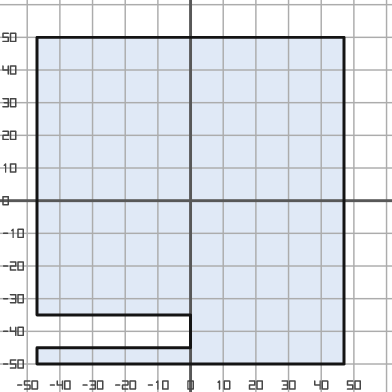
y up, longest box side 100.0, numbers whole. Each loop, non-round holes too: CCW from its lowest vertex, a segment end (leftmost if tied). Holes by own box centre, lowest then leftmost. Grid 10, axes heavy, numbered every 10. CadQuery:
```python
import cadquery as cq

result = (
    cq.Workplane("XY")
    .moveTo(-47.0, -50.0)
    .lineTo(47.0, -50.0)
    .lineTo(47.0, 50.0)
    .lineTo(-47.0, 50.0)
    .lineTo(-47.0, -35.0)
    .lineTo(0.0, -35.0)
    .lineTo(0.0, -45.0)
    .lineTo(-47.0, -45.0)
    .close()
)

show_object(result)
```